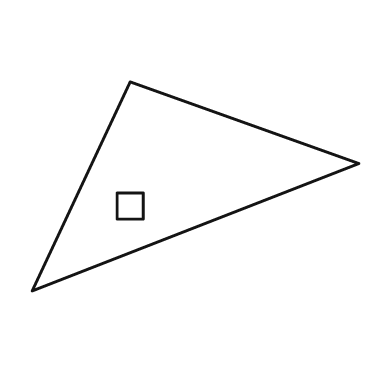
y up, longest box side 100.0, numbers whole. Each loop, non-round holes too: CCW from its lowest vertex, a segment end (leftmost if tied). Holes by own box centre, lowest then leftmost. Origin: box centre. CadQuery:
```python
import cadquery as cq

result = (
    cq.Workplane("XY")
    .moveTo(-50.0, -32.0)
    .lineTo(50.0, 7.0)
    .lineTo(-20.0, 32.0)
    .close()
    .moveTo(-24.0, -10.0)
    .lineTo(-16.0, -10.0)
    .lineTo(-16.0, -2.0)
    .lineTo(-24.0, -2.0)
    .close()
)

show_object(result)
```